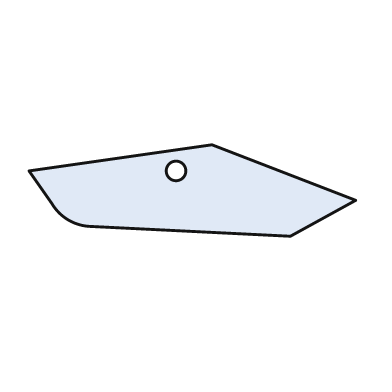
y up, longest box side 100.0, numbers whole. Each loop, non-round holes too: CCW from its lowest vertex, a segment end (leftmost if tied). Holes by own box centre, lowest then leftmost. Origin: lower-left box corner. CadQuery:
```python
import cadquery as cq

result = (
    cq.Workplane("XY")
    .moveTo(80.0, 0.0)
    .lineTo(100.0, 11.0)
    .lineTo(56.0, 28.0)
    .lineTo(0.0, 20.0)
    .lineTo(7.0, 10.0)
    .threePointArc((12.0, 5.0), (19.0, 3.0))
    .close()
    .moveTo(45.0, 20.0)
    .circle(3.0)
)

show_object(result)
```